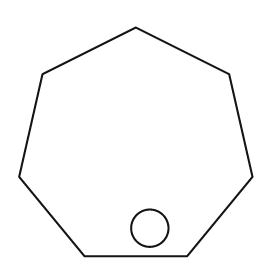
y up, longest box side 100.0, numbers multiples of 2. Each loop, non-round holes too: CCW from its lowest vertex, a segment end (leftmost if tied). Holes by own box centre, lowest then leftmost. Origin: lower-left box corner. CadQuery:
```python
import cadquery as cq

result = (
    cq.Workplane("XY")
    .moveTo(28.0, 0.0)
    .lineTo(72.0, 0.0)
    .lineTo(100.0, 34.0)
    .lineTo(90.0, 78.0)
    .lineTo(50.0, 98.0)
    .lineTo(10.0, 78.0)
    .lineTo(0.0, 34.0)
    .close()
    .moveTo(56.0, 12.0)
    .circle(8.0)
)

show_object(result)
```